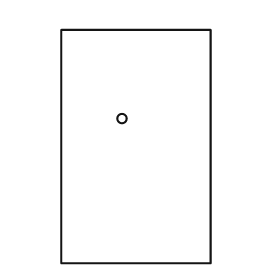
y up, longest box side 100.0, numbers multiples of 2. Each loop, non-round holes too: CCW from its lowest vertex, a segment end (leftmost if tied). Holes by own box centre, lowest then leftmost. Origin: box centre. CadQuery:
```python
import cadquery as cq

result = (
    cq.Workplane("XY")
    .moveTo(-32.0, -50.0)
    .lineTo(32.0, -50.0)
    .lineTo(32.0, 50.0)
    .lineTo(-32.0, 50.0)
    .close()
    .moveTo(-6.0, 12.0)
    .circle(2.0)
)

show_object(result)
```